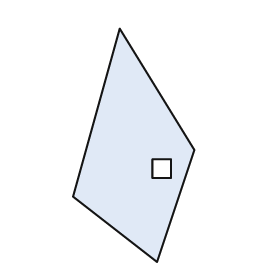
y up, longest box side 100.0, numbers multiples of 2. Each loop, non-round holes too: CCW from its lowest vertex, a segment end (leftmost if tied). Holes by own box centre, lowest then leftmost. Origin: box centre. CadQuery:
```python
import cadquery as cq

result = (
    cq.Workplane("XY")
    .moveTo(10.0, -50.0)
    .lineTo(26.0, -2.0)
    .lineTo(-6.0, 50.0)
    .lineTo(-26.0, -22.0)
    .close()
    .moveTo(8.0, -14.0)
    .lineTo(16.0, -14.0)
    .lineTo(16.0, -6.0)
    .lineTo(8.0, -6.0)
    .close()
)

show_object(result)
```